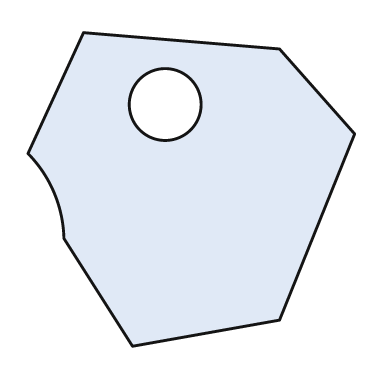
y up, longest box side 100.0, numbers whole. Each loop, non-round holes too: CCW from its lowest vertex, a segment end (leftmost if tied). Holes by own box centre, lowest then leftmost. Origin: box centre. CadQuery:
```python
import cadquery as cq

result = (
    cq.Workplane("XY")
    .moveTo(-18.0, -48.0)
    .lineTo(27.0, -40.0)
    .lineTo(50.0, 17.0)
    .lineTo(27.0, 43.0)
    .lineTo(-33.0, 48.0)
    .lineTo(-50.0, 11.0)
    .threePointArc((-42.0, -1.0), (-39.0, -15.0))
    .close()
    .moveTo(-8.0, 26.0)
    .circle(11.0)
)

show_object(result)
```